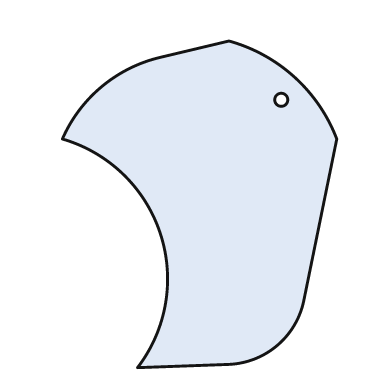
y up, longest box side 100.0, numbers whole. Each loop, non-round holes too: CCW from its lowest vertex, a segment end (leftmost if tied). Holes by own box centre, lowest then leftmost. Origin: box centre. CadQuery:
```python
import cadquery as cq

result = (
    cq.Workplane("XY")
    .moveTo(-19.0, -50.0)
    .lineTo(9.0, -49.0)
    .threePointArc((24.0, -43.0), (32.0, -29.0))
    .lineTo(42.0, 20.0)
    .threePointArc((29.0, 39.0), (9.0, 50.0))
    .lineTo(-12.0, 45.0)
    .threePointArc((-30.0, 36.0), (-42.0, 20.0))
    .threePointArc((-12.0, -9.0), (-19.0, -50.0))
    .close()
    .moveTo(25.0, 32.0)
    .circle(2.0)
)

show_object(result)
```